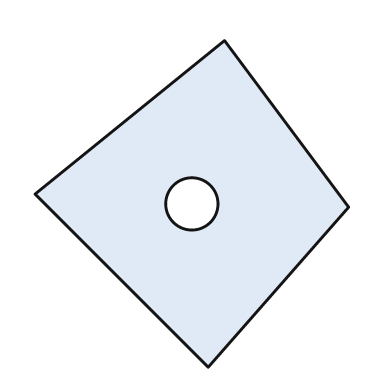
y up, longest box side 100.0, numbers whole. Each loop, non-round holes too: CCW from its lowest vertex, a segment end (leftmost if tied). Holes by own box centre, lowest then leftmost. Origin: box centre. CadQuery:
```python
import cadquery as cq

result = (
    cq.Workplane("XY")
    .moveTo(5.0, -50.0)
    .lineTo(48.0, -1.0)
    .lineTo(10.0, 50.0)
    .lineTo(-48.0, 3.0)
    .close()
    .moveTo(0.0, 0.0)
    .circle(8.0)
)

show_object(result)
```